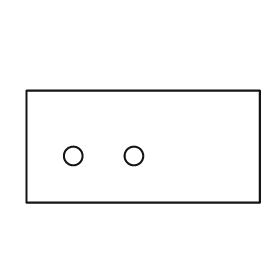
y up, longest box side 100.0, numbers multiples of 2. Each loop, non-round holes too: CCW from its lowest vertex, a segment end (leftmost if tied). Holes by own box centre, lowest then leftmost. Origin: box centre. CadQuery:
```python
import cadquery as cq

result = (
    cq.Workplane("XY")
    .moveTo(-50.0, -24.0)
    .lineTo(50.0, -24.0)
    .lineTo(50.0, 24.0)
    .lineTo(-50.0, 24.0)
    .close()
    .moveTo(-30.0, -4.0)
    .circle(4.0)
    .moveTo(-4.0, -4.0)
    .circle(4.0)
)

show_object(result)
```